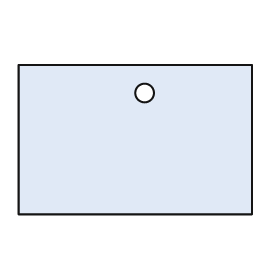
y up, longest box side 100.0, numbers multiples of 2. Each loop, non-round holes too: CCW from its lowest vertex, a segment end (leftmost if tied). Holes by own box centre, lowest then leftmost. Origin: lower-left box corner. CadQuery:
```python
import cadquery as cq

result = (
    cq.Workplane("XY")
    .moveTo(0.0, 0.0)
    .lineTo(100.0, 0.0)
    .lineTo(100.0, 64.0)
    .lineTo(0.0, 64.0)
    .close()
    .moveTo(54.0, 52.0)
    .circle(4.0)
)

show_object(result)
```